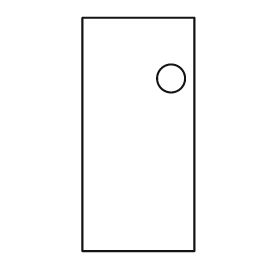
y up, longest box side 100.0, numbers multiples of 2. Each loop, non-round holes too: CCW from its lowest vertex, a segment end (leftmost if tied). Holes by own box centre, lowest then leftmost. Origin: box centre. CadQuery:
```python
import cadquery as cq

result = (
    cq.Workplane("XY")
    .moveTo(-24.0, -50.0)
    .lineTo(24.0, -50.0)
    .lineTo(24.0, 50.0)
    .lineTo(-24.0, 50.0)
    .close()
    .moveTo(14.0, 24.0)
    .circle(6.0)
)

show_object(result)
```